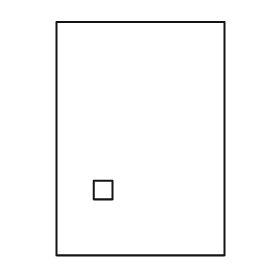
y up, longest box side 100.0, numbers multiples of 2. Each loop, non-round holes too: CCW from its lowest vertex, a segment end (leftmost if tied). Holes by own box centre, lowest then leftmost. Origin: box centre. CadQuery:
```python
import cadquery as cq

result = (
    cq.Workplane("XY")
    .moveTo(-36.0, -50.0)
    .lineTo(36.0, -50.0)
    .lineTo(36.0, 50.0)
    .lineTo(-36.0, 50.0)
    .close()
    .moveTo(-20.0, -26.0)
    .lineTo(-12.0, -26.0)
    .lineTo(-12.0, -18.0)
    .lineTo(-20.0, -18.0)
    .close()
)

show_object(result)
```